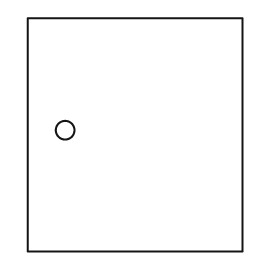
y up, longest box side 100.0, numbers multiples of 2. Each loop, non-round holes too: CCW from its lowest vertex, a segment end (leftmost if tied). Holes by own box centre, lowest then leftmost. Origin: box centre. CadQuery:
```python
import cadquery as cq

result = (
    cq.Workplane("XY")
    .moveTo(-46.0, -50.0)
    .lineTo(46.0, -50.0)
    .lineTo(46.0, 50.0)
    .lineTo(-46.0, 50.0)
    .close()
    .moveTo(-30.0, 2.0)
    .circle(4.0)
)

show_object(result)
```